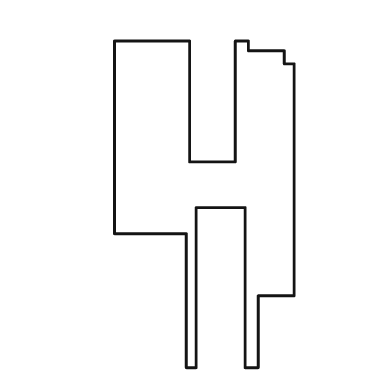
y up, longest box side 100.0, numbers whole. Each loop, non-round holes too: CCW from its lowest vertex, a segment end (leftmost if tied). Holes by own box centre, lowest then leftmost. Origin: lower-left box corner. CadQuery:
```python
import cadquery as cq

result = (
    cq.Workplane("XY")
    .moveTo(22.0, 0.0)
    .lineTo(25.0, 0.0)
    .lineTo(25.0, 49.0)
    .lineTo(40.0, 49.0)
    .lineTo(40.0, 0.0)
    .lineTo(44.0, 0.0)
    .lineTo(44.0, 22.0)
    .lineTo(55.0, 22.0)
    .lineTo(55.0, 93.0)
    .lineTo(52.0, 93.0)
    .lineTo(52.0, 97.0)
    .lineTo(41.0, 97.0)
    .lineTo(41.0, 100.0)
    .lineTo(37.0, 100.0)
    .lineTo(37.0, 63.0)
    .lineTo(23.0, 63.0)
    .lineTo(23.0, 100.0)
    .lineTo(0.0, 100.0)
    .lineTo(0.0, 41.0)
    .lineTo(22.0, 41.0)
    .close()
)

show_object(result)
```